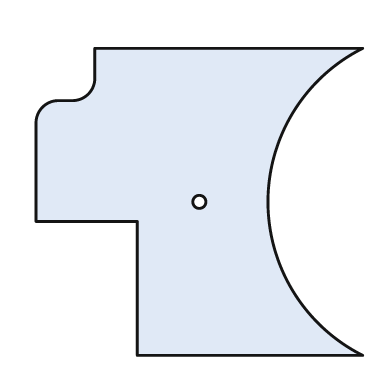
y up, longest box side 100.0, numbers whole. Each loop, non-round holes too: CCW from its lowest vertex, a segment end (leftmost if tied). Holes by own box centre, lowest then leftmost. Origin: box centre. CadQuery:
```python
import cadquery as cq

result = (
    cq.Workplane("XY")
    .moveTo(-19.0, -47.0)
    .lineTo(50.0, -47.0)
    .threePointArc((21.0, 0.0), (50.0, 47.0))
    .lineTo(-32.0, 47.0)
    .lineTo(-32.0, 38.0)
    .threePointArc((-34.0, 33.0), (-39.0, 31.0))
    .lineTo(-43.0, 31.0)
    .threePointArc((-48.0, 29.0), (-50.0, 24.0))
    .lineTo(-50.0, -6.0)
    .lineTo(-19.0, -6.0)
    .close()
    .moveTo(0.0, 0.0)
    .circle(2.0)
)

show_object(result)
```